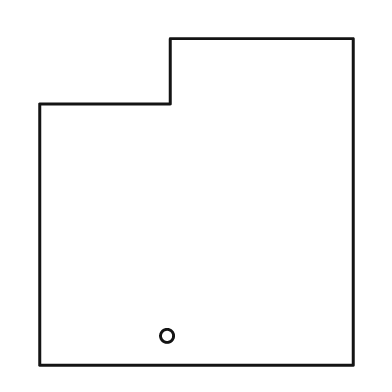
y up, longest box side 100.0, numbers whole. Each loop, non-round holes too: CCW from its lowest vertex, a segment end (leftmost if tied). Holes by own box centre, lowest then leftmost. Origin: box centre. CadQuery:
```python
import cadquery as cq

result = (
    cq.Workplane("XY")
    .moveTo(-48.0, -50.0)
    .lineTo(48.0, -50.0)
    .lineTo(48.0, 50.0)
    .lineTo(-8.0, 50.0)
    .lineTo(-8.0, 30.0)
    .lineTo(-48.0, 30.0)
    .close()
    .moveTo(-9.0, -41.0)
    .circle(2.0)
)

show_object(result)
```